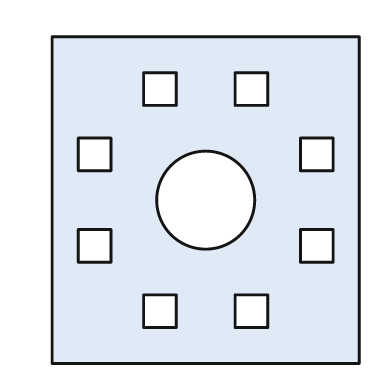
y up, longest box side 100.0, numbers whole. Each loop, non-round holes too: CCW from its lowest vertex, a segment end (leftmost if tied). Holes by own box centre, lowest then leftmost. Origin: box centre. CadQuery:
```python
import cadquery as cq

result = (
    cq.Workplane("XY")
    .moveTo(-47.0, -50.0)
    .lineTo(47.0, -50.0)
    .lineTo(47.0, 50.0)
    .lineTo(-47.0, 50.0)
    .close()
    .moveTo(-19.0, -39.0)
    .lineTo(-9.0, -39.0)
    .lineTo(-9.0, -29.0)
    .lineTo(-19.0, -29.0)
    .close()
    .moveTo(9.0, -39.0)
    .lineTo(19.0, -39.0)
    .lineTo(19.0, -29.0)
    .lineTo(9.0, -29.0)
    .close()
    .moveTo(-39.0, -19.0)
    .lineTo(-29.0, -19.0)
    .lineTo(-29.0, -9.0)
    .lineTo(-39.0, -9.0)
    .close()
    .moveTo(29.0, -19.0)
    .lineTo(39.0, -19.0)
    .lineTo(39.0, -9.0)
    .lineTo(29.0, -9.0)
    .close()
    .moveTo(0.0, 0.0)
    .circle(15.0)
    .moveTo(-39.0, 9.0)
    .lineTo(-29.0, 9.0)
    .lineTo(-29.0, 19.0)
    .lineTo(-39.0, 19.0)
    .close()
    .moveTo(29.0, 9.0)
    .lineTo(39.0, 9.0)
    .lineTo(39.0, 19.0)
    .lineTo(29.0, 19.0)
    .close()
    .moveTo(-19.0, 29.0)
    .lineTo(-9.0, 29.0)
    .lineTo(-9.0, 39.0)
    .lineTo(-19.0, 39.0)
    .close()
    .moveTo(9.0, 29.0)
    .lineTo(19.0, 29.0)
    .lineTo(19.0, 39.0)
    .lineTo(9.0, 39.0)
    .close()
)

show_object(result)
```